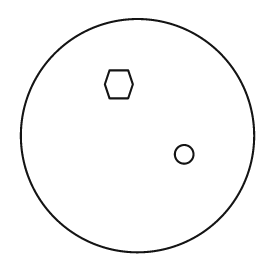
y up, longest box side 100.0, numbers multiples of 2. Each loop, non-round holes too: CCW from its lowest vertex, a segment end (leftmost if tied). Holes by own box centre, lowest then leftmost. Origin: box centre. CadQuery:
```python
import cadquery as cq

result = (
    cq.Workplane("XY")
    .moveTo(0.0, 0.0)
    .circle(50.0)
    .moveTo(20.0, -8.0)
    .circle(4.0)
    .moveTo(-12.0, 16.0)
    .lineTo(-4.0, 16.0)
    .lineTo(-2.0, 22.0)
    .lineTo(-4.0, 28.0)
    .lineTo(-12.0, 28.0)
    .lineTo(-14.0, 22.0)
    .close()
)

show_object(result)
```